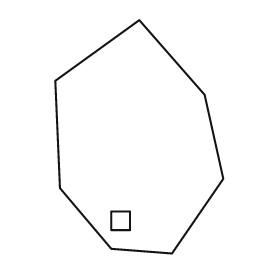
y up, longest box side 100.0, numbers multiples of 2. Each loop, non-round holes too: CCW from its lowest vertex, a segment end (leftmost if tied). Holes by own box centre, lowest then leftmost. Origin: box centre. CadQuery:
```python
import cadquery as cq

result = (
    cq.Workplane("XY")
    .moveTo(14.0, -50.0)
    .lineTo(36.0, -18.0)
    .lineTo(28.0, 18.0)
    .lineTo(0.0, 50.0)
    .lineTo(-36.0, 24.0)
    .lineTo(-34.0, -22.0)
    .lineTo(-12.0, -48.0)
    .close()
    .moveTo(-12.0, -40.0)
    .lineTo(-4.0, -40.0)
    .lineTo(-4.0, -32.0)
    .lineTo(-12.0, -32.0)
    .close()
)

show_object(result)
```